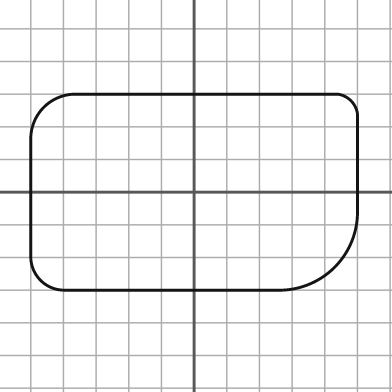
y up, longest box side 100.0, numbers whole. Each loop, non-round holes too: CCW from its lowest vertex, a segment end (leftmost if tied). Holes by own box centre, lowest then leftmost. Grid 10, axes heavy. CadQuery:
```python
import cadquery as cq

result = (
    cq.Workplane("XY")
    .moveTo(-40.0, -30.0)
    .lineTo(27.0, -30.0)
    .threePointArc((43.0, -23.0), (50.0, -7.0))
    .lineTo(50.0, 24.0)
    .threePointArc((48.0, 28.0), (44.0, 30.0))
    .lineTo(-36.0, 30.0)
    .threePointArc((-46.0, 26.0), (-50.0, 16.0))
    .lineTo(-50.0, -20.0)
    .threePointArc((-47.0, -27.0), (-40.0, -30.0))
    .close()
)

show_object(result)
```